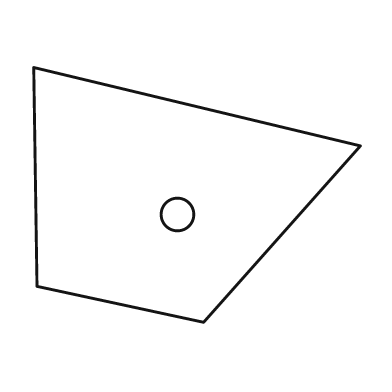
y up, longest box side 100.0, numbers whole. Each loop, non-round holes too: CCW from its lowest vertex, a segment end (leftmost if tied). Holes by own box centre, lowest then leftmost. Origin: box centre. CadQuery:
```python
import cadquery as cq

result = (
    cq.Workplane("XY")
    .moveTo(2.0, -39.0)
    .lineTo(50.0, 15.0)
    .lineTo(-50.0, 39.0)
    .lineTo(-49.0, -28.0)
    .close()
    .moveTo(-6.0, -6.0)
    .circle(5.0)
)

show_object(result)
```